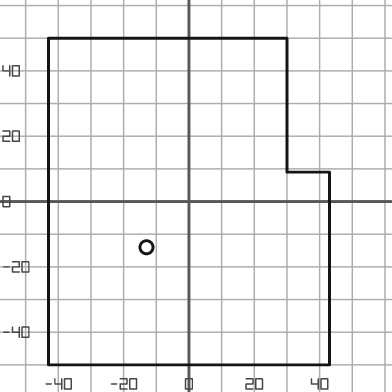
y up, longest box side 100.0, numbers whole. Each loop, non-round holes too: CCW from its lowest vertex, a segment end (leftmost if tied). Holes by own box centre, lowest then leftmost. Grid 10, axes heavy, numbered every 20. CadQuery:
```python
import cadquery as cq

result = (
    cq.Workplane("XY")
    .moveTo(-43.0, -50.0)
    .lineTo(43.0, -50.0)
    .lineTo(43.0, 9.0)
    .lineTo(30.0, 9.0)
    .lineTo(30.0, 50.0)
    .lineTo(-43.0, 50.0)
    .close()
    .moveTo(-13.0, -14.0)
    .circle(2.0)
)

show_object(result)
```